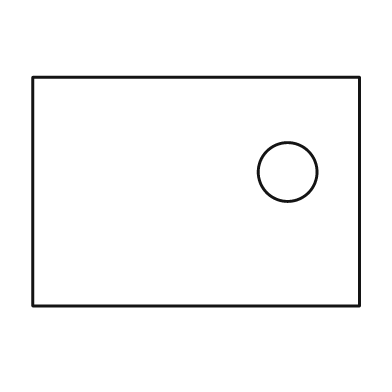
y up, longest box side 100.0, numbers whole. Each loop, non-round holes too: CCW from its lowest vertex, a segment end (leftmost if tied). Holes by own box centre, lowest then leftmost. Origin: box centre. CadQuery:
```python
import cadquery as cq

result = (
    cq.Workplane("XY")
    .moveTo(-50.0, -35.0)
    .lineTo(50.0, -35.0)
    .lineTo(50.0, 35.0)
    .lineTo(-50.0, 35.0)
    .close()
    .moveTo(28.0, 6.0)
    .circle(9.0)
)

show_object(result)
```